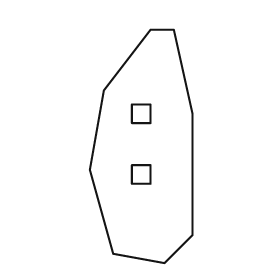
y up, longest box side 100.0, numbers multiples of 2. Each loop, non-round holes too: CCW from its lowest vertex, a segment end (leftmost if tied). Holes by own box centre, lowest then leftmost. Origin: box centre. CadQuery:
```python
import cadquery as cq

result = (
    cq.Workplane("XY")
    .moveTo(10.0, -50.0)
    .lineTo(22.0, -38.0)
    .lineTo(22.0, 14.0)
    .lineTo(14.0, 50.0)
    .lineTo(4.0, 50.0)
    .lineTo(-16.0, 24.0)
    .lineTo(-22.0, -10.0)
    .lineTo(-12.0, -46.0)
    .close()
    .moveTo(-4.0, -16.0)
    .lineTo(4.0, -16.0)
    .lineTo(4.0, -8.0)
    .lineTo(-4.0, -8.0)
    .close()
    .moveTo(-4.0, 10.0)
    .lineTo(4.0, 10.0)
    .lineTo(4.0, 18.0)
    .lineTo(-4.0, 18.0)
    .close()
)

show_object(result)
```